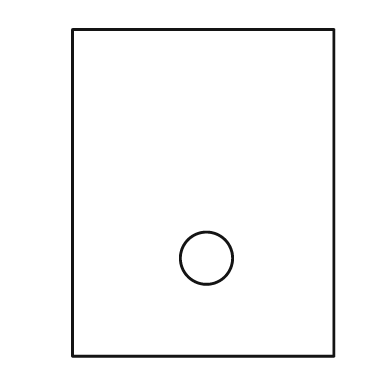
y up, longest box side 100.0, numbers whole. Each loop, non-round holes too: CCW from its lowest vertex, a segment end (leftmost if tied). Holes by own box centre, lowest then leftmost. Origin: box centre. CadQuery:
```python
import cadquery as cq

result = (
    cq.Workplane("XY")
    .moveTo(-40.0, -50.0)
    .lineTo(40.0, -50.0)
    .lineTo(40.0, 50.0)
    .lineTo(-40.0, 50.0)
    .close()
    .moveTo(1.0, -20.0)
    .circle(8.0)
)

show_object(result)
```